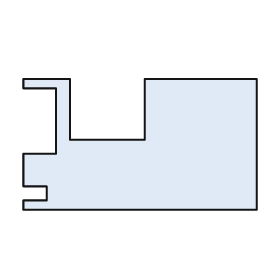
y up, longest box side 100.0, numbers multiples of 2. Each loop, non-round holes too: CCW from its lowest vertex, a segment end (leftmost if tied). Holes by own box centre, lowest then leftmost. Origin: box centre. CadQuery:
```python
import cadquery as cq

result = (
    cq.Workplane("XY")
    .moveTo(-50.0, -28.0)
    .lineTo(50.0, -28.0)
    .lineTo(50.0, 28.0)
    .lineTo(2.0, 28.0)
    .lineTo(2.0, 2.0)
    .lineTo(-30.0, 2.0)
    .lineTo(-30.0, 28.0)
    .lineTo(-50.0, 28.0)
    .lineTo(-50.0, 24.0)
    .lineTo(-36.0, 24.0)
    .lineTo(-36.0, -4.0)
    .lineTo(-50.0, -4.0)
    .lineTo(-50.0, -18.0)
    .lineTo(-40.0, -18.0)
    .lineTo(-40.0, -24.0)
    .lineTo(-50.0, -24.0)
    .close()
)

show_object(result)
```